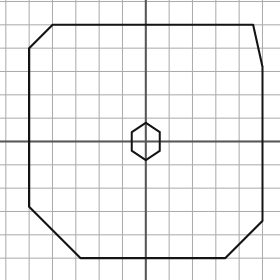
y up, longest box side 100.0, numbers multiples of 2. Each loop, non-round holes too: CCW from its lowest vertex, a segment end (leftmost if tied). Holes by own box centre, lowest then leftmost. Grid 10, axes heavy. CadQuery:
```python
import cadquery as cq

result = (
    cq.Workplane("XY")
    .moveTo(-28.0, -50.0)
    .lineTo(34.0, -50.0)
    .lineTo(50.0, -34.0)
    .lineTo(50.0, 32.0)
    .lineTo(46.0, 50.0)
    .lineTo(-40.0, 50.0)
    .lineTo(-50.0, 40.0)
    .lineTo(-50.0, -28.0)
    .close()
    .moveTo(0.0, -8.0)
    .lineTo(6.0, -4.0)
    .lineTo(6.0, 4.0)
    .lineTo(0.0, 8.0)
    .lineTo(-6.0, 4.0)
    .lineTo(-6.0, -4.0)
    .close()
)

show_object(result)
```